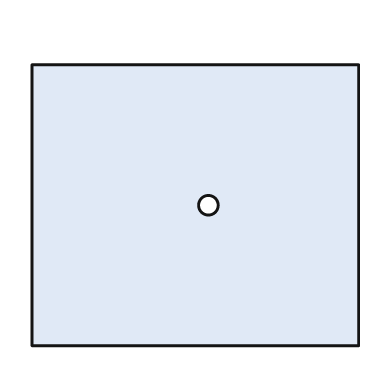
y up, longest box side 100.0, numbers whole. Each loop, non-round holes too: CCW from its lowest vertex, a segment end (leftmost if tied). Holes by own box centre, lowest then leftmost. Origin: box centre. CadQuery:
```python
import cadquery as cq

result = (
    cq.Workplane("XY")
    .moveTo(-50.0, -43.0)
    .lineTo(50.0, -43.0)
    .lineTo(50.0, 43.0)
    .lineTo(-50.0, 43.0)
    .close()
    .moveTo(4.0, 0.0)
    .circle(3.0)
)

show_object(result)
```